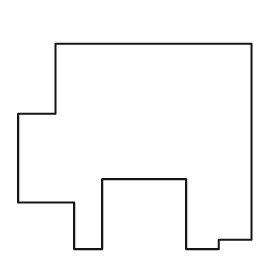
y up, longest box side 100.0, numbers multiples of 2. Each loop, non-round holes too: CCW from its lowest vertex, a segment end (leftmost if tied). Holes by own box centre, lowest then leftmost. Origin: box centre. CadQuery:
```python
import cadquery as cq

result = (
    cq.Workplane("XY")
    .moveTo(-26.0, -44.0)
    .lineTo(-14.0, -44.0)
    .lineTo(-14.0, -14.0)
    .lineTo(22.0, -14.0)
    .lineTo(22.0, -44.0)
    .lineTo(36.0, -44.0)
    .lineTo(36.0, -40.0)
    .lineTo(50.0, -40.0)
    .lineTo(50.0, 44.0)
    .lineTo(-34.0, 44.0)
    .lineTo(-34.0, 14.0)
    .lineTo(-50.0, 14.0)
    .lineTo(-50.0, -24.0)
    .lineTo(-26.0, -24.0)
    .close()
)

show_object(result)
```